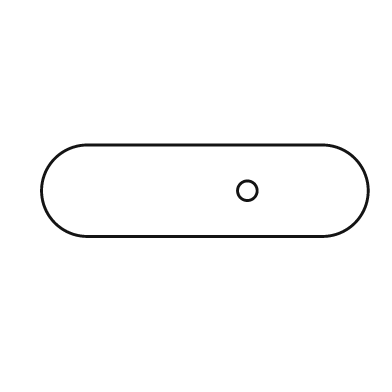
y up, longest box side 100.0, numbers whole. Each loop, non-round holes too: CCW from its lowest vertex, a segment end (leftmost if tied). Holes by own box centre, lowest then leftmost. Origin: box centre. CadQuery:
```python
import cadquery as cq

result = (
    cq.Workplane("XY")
    .moveTo(-36.0, -14.0)
    .lineTo(36.0, -14.0)
    .threePointArc((50.0, 0.0), (36.0, 14.0))
    .lineTo(-36.0, 14.0)
    .threePointArc((-50.0, 0.0), (-36.0, -14.0))
    .close()
    .moveTo(13.0, 0.0)
    .circle(3.0)
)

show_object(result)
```